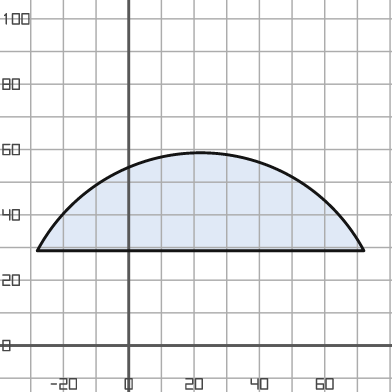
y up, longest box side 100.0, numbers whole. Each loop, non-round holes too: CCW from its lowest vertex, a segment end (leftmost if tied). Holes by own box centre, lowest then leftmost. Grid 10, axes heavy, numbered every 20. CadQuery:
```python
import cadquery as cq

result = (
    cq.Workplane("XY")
    .moveTo(-28.0, 29.0)
    .lineTo(72.0, 29.0)
    .threePointArc((22.0, 59.0), (-28.0, 29.0))
    .close()
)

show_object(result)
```